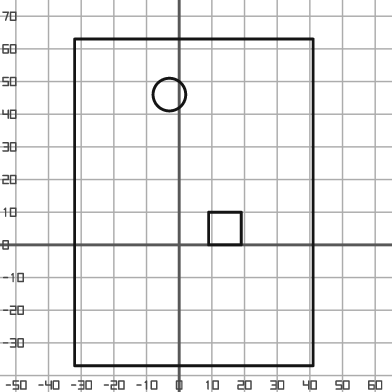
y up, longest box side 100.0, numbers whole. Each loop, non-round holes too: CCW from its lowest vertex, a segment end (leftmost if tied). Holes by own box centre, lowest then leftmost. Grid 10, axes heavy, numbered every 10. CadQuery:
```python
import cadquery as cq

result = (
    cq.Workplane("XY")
    .moveTo(-32.0, -37.0)
    .lineTo(41.0, -37.0)
    .lineTo(41.0, 63.0)
    .lineTo(-32.0, 63.0)
    .close()
    .moveTo(9.0, 0.0)
    .lineTo(19.0, 0.0)
    .lineTo(19.0, 10.0)
    .lineTo(9.0, 10.0)
    .close()
    .moveTo(-3.0, 46.0)
    .circle(5.0)
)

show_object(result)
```